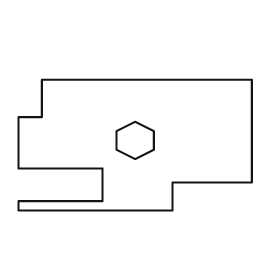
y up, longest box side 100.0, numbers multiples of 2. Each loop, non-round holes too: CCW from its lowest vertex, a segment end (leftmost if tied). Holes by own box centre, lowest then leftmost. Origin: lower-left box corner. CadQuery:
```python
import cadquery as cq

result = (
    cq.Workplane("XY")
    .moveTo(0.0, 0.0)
    .lineTo(66.0, 0.0)
    .lineTo(66.0, 12.0)
    .lineTo(100.0, 12.0)
    .lineTo(100.0, 56.0)
    .lineTo(10.0, 56.0)
    .lineTo(10.0, 40.0)
    .lineTo(0.0, 40.0)
    .lineTo(0.0, 18.0)
    .lineTo(36.0, 18.0)
    .lineTo(36.0, 4.0)
    .lineTo(0.0, 4.0)
    .close()
    .moveTo(50.0, 22.0)
    .lineTo(58.0, 26.0)
    .lineTo(58.0, 34.0)
    .lineTo(50.0, 38.0)
    .lineTo(42.0, 34.0)
    .lineTo(42.0, 26.0)
    .close()
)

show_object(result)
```